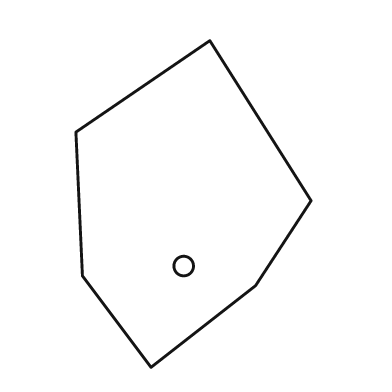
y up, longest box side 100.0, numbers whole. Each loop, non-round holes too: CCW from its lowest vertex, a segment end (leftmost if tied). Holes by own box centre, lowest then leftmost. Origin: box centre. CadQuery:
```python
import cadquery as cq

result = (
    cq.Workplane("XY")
    .moveTo(-13.0, -50.0)
    .lineTo(19.0, -25.0)
    .lineTo(36.0, 1.0)
    .lineTo(5.0, 50.0)
    .lineTo(-36.0, 22.0)
    .lineTo(-34.0, -22.0)
    .close()
    .moveTo(-3.0, -19.0)
    .circle(3.0)
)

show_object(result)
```